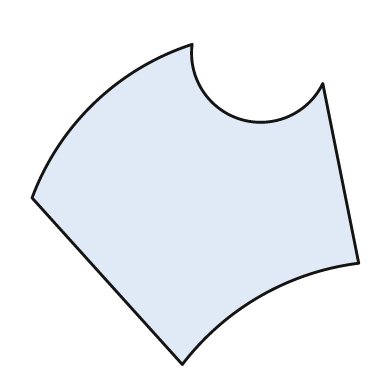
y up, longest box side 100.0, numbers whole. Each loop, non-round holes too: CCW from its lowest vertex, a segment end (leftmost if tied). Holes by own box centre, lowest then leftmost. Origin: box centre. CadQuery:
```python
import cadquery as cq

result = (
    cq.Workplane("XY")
    .moveTo(-4.0, -49.0)
    .threePointArc((20.0, -28.0), (50.0, -18.0))
    .lineTo(39.0, 37.0)
    .threePointArc((14.0, 26.0), (-1.0, 49.0))
    .threePointArc((-31.0, 31.0), (-50.0, 2.0))
    .close()
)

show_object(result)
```